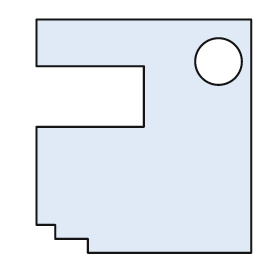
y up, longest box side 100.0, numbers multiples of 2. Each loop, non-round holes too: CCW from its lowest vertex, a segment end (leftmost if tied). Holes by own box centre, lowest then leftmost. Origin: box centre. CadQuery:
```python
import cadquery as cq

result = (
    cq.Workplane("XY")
    .moveTo(-24.0, -50.0)
    .lineTo(46.0, -50.0)
    .lineTo(46.0, 50.0)
    .lineTo(-46.0, 50.0)
    .lineTo(-46.0, 30.0)
    .lineTo(0.0, 30.0)
    .lineTo(0.0, 4.0)
    .lineTo(-46.0, 4.0)
    .lineTo(-46.0, -38.0)
    .lineTo(-38.0, -38.0)
    .lineTo(-38.0, -44.0)
    .lineTo(-24.0, -44.0)
    .close()
    .moveTo(32.0, 32.0)
    .circle(10.0)
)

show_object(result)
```